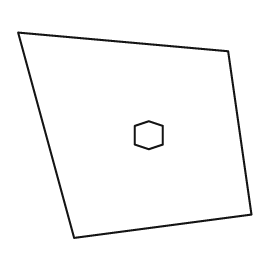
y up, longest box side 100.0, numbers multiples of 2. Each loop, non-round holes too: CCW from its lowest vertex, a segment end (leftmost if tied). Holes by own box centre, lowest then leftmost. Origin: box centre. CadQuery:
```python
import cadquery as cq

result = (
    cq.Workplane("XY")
    .moveTo(-26.0, -44.0)
    .lineTo(50.0, -34.0)
    .lineTo(40.0, 36.0)
    .lineTo(-50.0, 44.0)
    .close()
    .moveTo(6.0, -6.0)
    .lineTo(12.0, -4.0)
    .lineTo(12.0, 4.0)
    .lineTo(6.0, 6.0)
    .lineTo(0.0, 4.0)
    .lineTo(0.0, -4.0)
    .close()
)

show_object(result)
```